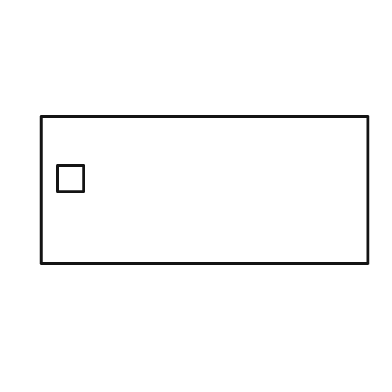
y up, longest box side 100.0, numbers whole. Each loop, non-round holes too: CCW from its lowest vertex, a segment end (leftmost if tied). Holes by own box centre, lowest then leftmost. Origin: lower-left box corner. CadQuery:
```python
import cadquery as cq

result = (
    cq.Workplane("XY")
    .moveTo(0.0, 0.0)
    .lineTo(100.0, 0.0)
    .lineTo(100.0, 45.0)
    .lineTo(0.0, 45.0)
    .close()
    .moveTo(5.0, 22.0)
    .lineTo(13.0, 22.0)
    .lineTo(13.0, 30.0)
    .lineTo(5.0, 30.0)
    .close()
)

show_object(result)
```